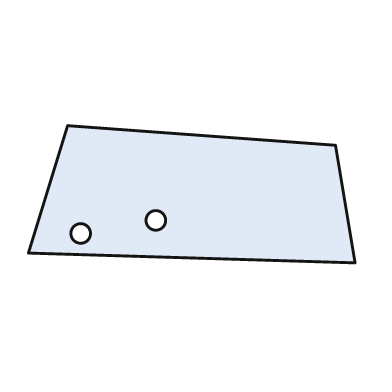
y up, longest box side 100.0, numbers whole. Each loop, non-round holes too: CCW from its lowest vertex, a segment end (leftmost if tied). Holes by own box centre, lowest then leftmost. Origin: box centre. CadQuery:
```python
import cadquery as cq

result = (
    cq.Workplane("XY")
    .moveTo(50.0, -21.0)
    .lineTo(44.0, 15.0)
    .lineTo(-38.0, 21.0)
    .lineTo(-50.0, -18.0)
    .close()
    .moveTo(-34.0, -12.0)
    .circle(3.0)
    .moveTo(-11.0, -8.0)
    .circle(3.0)
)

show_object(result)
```